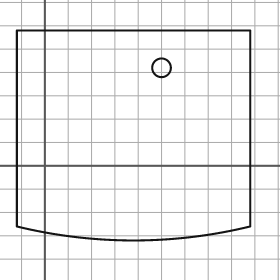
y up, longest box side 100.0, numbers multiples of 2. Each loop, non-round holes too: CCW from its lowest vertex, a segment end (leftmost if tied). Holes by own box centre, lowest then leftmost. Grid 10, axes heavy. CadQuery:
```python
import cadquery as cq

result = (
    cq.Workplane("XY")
    .moveTo(-12.0, -26.0)
    .threePointArc((38.0, -32.0), (88.0, -26.0))
    .lineTo(88.0, 58.0)
    .lineTo(-12.0, 58.0)
    .close()
    .moveTo(50.0, 42.0)
    .circle(4.0)
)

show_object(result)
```